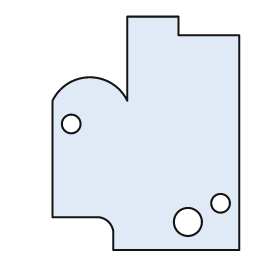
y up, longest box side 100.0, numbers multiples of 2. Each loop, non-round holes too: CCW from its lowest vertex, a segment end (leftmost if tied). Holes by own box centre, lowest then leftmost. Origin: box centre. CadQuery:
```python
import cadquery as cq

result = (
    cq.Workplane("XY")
    .moveTo(-14.0, -50.0)
    .lineTo(40.0, -50.0)
    .lineTo(40.0, 42.0)
    .lineTo(14.0, 42.0)
    .lineTo(14.0, 50.0)
    .lineTo(-8.0, 50.0)
    .lineTo(-8.0, 14.0)
    .threePointArc((-24.0, 24.0), (-40.0, 14.0))
    .lineTo(-40.0, -36.0)
    .lineTo(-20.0, -36.0)
    .threePointArc((-16.0, -38.0), (-14.0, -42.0))
    .close()
    .moveTo(18.0, -38.0)
    .circle(6.0)
    .moveTo(32.0, -30.0)
    .circle(4.0)
    .moveTo(-32.0, 4.0)
    .circle(4.0)
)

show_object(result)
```